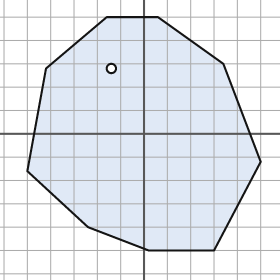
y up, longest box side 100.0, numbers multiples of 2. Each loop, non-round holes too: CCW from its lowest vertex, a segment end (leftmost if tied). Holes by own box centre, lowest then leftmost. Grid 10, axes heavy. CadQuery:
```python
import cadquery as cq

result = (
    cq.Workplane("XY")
    .moveTo(2.0, -50.0)
    .lineTo(30.0, -50.0)
    .lineTo(50.0, -12.0)
    .lineTo(34.0, 30.0)
    .lineTo(6.0, 50.0)
    .lineTo(-16.0, 50.0)
    .lineTo(-42.0, 28.0)
    .lineTo(-50.0, -16.0)
    .lineTo(-24.0, -40.0)
    .close()
    .moveTo(-14.0, 28.0)
    .circle(2.0)
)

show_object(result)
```